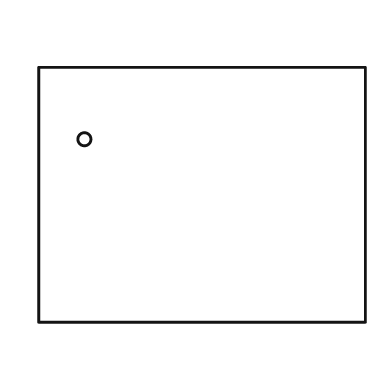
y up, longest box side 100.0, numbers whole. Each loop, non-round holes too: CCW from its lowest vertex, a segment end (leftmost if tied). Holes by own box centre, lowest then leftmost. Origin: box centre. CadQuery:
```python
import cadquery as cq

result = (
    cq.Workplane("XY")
    .moveTo(-50.0, -39.0)
    .lineTo(50.0, -39.0)
    .lineTo(50.0, 39.0)
    .lineTo(-50.0, 39.0)
    .close()
    .moveTo(-36.0, 17.0)
    .circle(2.0)
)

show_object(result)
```